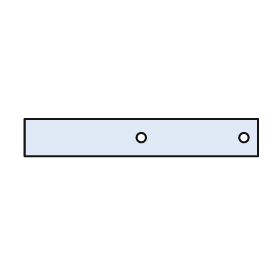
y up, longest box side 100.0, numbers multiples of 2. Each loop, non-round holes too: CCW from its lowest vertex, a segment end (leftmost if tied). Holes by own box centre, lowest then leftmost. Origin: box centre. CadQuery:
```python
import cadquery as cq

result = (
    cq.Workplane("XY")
    .moveTo(-50.0, -8.0)
    .lineTo(50.0, -8.0)
    .lineTo(50.0, 8.0)
    .lineTo(-50.0, 8.0)
    .close()
    .moveTo(0.0, 0.0)
    .circle(2.0)
    .moveTo(44.0, 0.0)
    .circle(2.0)
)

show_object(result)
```